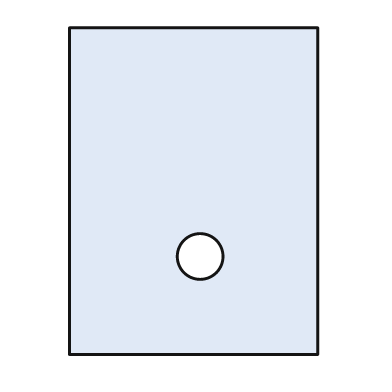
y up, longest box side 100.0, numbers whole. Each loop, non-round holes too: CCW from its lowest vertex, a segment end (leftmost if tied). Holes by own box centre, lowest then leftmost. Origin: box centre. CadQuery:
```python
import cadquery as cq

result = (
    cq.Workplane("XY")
    .moveTo(-38.0, -50.0)
    .lineTo(38.0, -50.0)
    .lineTo(38.0, 50.0)
    .lineTo(-38.0, 50.0)
    .close()
    .moveTo(2.0, -20.0)
    .circle(7.0)
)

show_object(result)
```